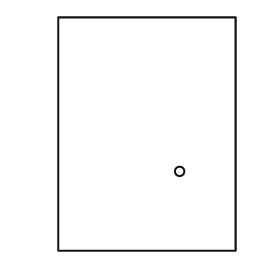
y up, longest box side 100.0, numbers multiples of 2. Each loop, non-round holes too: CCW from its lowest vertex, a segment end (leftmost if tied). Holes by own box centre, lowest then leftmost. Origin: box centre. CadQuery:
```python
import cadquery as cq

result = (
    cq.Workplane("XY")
    .moveTo(-38.0, -50.0)
    .lineTo(38.0, -50.0)
    .lineTo(38.0, 50.0)
    .lineTo(-38.0, 50.0)
    .close()
    .moveTo(14.0, -16.0)
    .circle(2.0)
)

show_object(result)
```